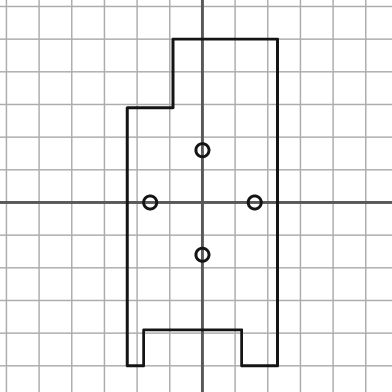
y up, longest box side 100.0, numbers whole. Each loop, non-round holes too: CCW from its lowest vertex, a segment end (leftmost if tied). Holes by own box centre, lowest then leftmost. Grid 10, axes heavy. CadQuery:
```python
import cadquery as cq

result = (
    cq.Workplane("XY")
    .moveTo(-23.0, -50.0)
    .lineTo(-18.0, -50.0)
    .lineTo(-18.0, -39.0)
    .lineTo(12.0, -39.0)
    .lineTo(12.0, -50.0)
    .lineTo(23.0, -50.0)
    .lineTo(23.0, 50.0)
    .lineTo(-9.0, 50.0)
    .lineTo(-9.0, 29.0)
    .lineTo(-23.0, 29.0)
    .close()
    .moveTo(0.0, -16.0)
    .circle(2.0)
    .moveTo(-16.0, 0.0)
    .circle(2.0)
    .moveTo(16.0, 0.0)
    .circle(2.0)
    .moveTo(0.0, 16.0)
    .circle(2.0)
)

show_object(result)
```